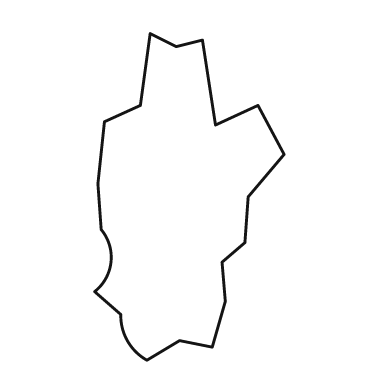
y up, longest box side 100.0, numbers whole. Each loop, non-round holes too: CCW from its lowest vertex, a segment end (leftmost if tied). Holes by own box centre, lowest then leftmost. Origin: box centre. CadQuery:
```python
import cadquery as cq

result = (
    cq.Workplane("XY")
    .moveTo(-13.0, -50.0)
    .lineTo(-3.0, -44.0)
    .lineTo(7.0, -46.0)
    .lineTo(11.0, -32.0)
    .lineTo(10.0, -20.0)
    .lineTo(17.0, -14.0)
    .lineTo(18.0, 0.0)
    .lineTo(29.0, 13.0)
    .lineTo(21.0, 28.0)
    .lineTo(8.0, 22.0)
    .lineTo(4.0, 48.0)
    .lineTo(-4.0, 46.0)
    .lineTo(-12.0, 50.0)
    .lineTo(-15.0, 28.0)
    .lineTo(-26.0, 23.0)
    .lineTo(-28.0, 4.0)
    .lineTo(-27.0, -10.0)
    .threePointArc((-24.0, -20.0), (-29.0, -29.0))
    .lineTo(-21.0, -36.0)
    .threePointArc((-19.0, -44.0), (-13.0, -50.0))
    .close()
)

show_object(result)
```